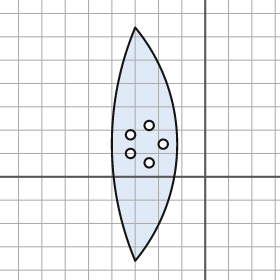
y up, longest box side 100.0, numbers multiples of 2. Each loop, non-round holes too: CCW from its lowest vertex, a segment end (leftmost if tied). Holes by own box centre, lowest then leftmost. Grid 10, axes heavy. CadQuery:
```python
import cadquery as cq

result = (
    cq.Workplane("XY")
    .moveTo(-30.0, -36.0)
    .threePointArc((-12.0, 14.0), (-30.0, 64.0))
    .threePointArc((-40.0, 14.0), (-30.0, -36.0))
    .close()
    .moveTo(-24.0, 6.0)
    .circle(2.0)
    .moveTo(-32.0, 10.0)
    .circle(2.0)
    .moveTo(-18.0, 14.0)
    .circle(2.0)
    .moveTo(-32.0, 18.0)
    .circle(2.0)
    .moveTo(-24.0, 22.0)
    .circle(2.0)
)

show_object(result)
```